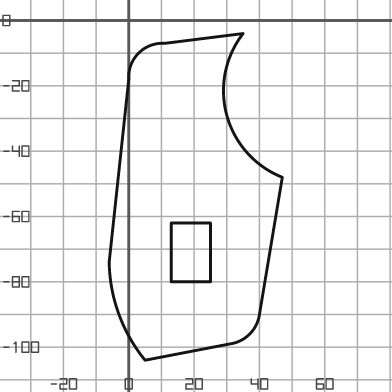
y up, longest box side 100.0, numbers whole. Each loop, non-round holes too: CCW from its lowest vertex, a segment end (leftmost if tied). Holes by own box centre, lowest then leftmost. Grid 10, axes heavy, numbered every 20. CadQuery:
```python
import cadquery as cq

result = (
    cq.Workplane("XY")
    .moveTo(5.0, -104.0)
    .lineTo(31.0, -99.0)
    .threePointArc((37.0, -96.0), (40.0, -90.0))
    .lineTo(47.0, -48.0)
    .threePointArc((30.0, -29.0), (35.0, -4.0))
    .lineTo(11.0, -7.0)
    .threePointArc((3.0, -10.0), (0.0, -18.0))
    .lineTo(-6.0, -74.0)
    .threePointArc((-3.0, -90.0), (5.0, -104.0))
    .close()
    .moveTo(13.0, -80.0)
    .lineTo(25.0, -80.0)
    .lineTo(25.0, -62.0)
    .lineTo(13.0, -62.0)
    .close()
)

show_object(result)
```